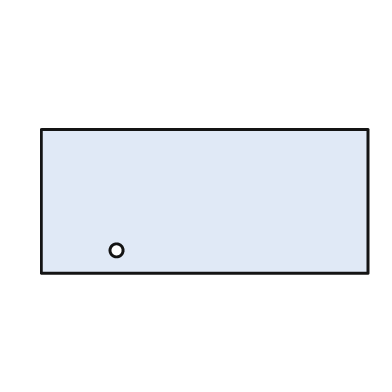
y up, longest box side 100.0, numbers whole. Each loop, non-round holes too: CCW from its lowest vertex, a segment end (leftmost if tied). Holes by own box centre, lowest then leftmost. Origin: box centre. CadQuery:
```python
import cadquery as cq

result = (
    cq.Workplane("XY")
    .moveTo(-50.0, -22.0)
    .lineTo(50.0, -22.0)
    .lineTo(50.0, 22.0)
    .lineTo(-50.0, 22.0)
    .close()
    .moveTo(-27.0, -15.0)
    .circle(2.0)
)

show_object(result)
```